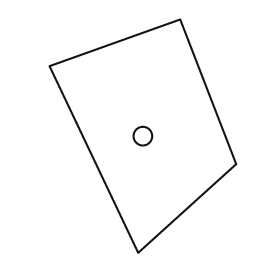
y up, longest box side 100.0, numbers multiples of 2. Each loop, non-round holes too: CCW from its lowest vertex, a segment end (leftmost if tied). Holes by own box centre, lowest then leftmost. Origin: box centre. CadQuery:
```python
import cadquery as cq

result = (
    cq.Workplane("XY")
    .moveTo(-2.0, -50.0)
    .lineTo(40.0, -12.0)
    .lineTo(16.0, 50.0)
    .lineTo(-40.0, 30.0)
    .close()
    .moveTo(0.0, 0.0)
    .circle(4.0)
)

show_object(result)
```